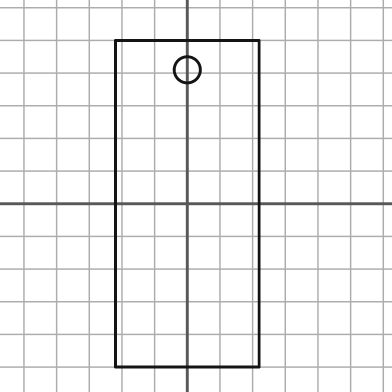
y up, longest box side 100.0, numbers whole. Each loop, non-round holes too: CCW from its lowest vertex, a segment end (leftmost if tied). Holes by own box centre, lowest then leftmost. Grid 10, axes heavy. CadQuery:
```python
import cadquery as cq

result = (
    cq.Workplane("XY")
    .moveTo(-22.0, -50.0)
    .lineTo(22.0, -50.0)
    .lineTo(22.0, 50.0)
    .lineTo(-22.0, 50.0)
    .close()
    .moveTo(0.0, 41.0)
    .circle(4.0)
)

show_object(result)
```